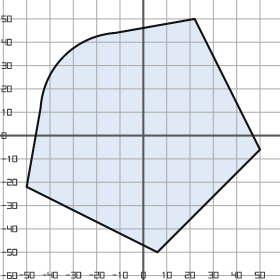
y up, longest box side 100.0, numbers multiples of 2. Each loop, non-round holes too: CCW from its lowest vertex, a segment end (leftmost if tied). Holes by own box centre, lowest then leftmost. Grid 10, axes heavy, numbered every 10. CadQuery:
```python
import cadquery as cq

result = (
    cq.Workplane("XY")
    .moveTo(6.0, -50.0)
    .lineTo(50.0, -6.0)
    .lineTo(22.0, 50.0)
    .lineTo(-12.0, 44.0)
    .threePointArc((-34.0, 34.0), (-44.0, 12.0))
    .lineTo(-50.0, -22.0)
    .close()
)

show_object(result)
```